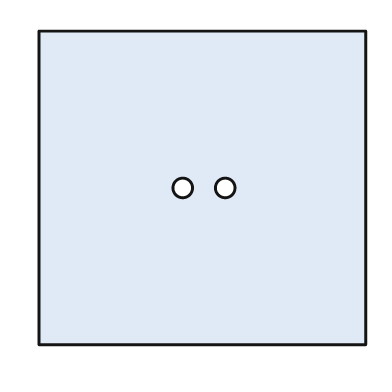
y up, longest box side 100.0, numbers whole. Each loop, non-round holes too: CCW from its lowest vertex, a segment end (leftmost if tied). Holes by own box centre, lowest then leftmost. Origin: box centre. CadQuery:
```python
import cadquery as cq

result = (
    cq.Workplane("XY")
    .moveTo(-50.0, -48.0)
    .lineTo(50.0, -48.0)
    .lineTo(50.0, 48.0)
    .lineTo(-50.0, 48.0)
    .close()
    .moveTo(-6.0, 0.0)
    .circle(3.0)
    .moveTo(7.0, 0.0)
    .circle(3.0)
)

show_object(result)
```